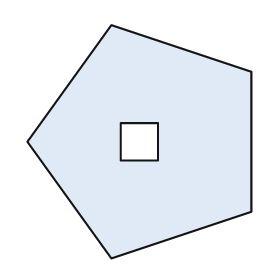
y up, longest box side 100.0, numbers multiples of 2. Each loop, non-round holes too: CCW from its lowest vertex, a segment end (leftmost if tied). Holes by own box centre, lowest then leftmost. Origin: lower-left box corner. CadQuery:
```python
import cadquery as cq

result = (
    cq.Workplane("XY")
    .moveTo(36.0, 0.0)
    .lineTo(96.0, 20.0)
    .lineTo(96.0, 80.0)
    .lineTo(36.0, 100.0)
    .lineTo(0.0, 50.0)
    .close()
    .moveTo(40.0, 42.0)
    .lineTo(56.0, 42.0)
    .lineTo(56.0, 58.0)
    .lineTo(40.0, 58.0)
    .close()
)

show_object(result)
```